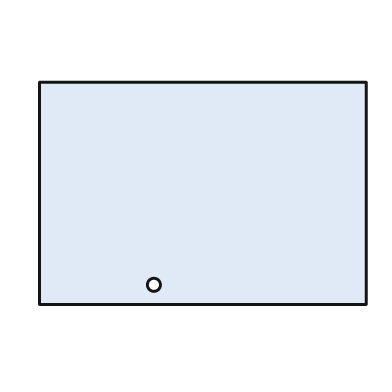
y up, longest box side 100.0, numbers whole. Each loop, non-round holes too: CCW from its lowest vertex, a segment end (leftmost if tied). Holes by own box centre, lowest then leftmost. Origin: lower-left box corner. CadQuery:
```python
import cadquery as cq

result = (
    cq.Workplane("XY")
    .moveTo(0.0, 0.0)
    .lineTo(100.0, 0.0)
    .lineTo(100.0, 68.0)
    .lineTo(0.0, 68.0)
    .close()
    .moveTo(35.0, 6.0)
    .circle(2.0)
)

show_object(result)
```